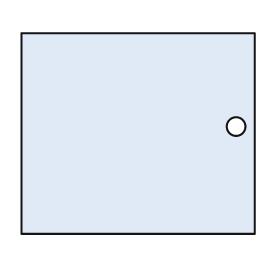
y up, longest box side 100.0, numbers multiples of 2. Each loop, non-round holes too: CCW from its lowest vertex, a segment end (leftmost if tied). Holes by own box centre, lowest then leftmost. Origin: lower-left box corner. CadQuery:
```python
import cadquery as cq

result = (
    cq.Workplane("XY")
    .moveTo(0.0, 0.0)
    .lineTo(100.0, 0.0)
    .lineTo(100.0, 86.0)
    .lineTo(0.0, 86.0)
    .close()
    .moveTo(92.0, 46.0)
    .circle(4.0)
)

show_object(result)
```